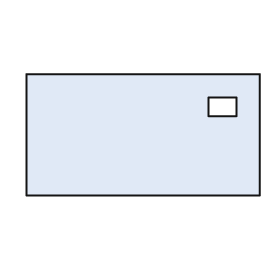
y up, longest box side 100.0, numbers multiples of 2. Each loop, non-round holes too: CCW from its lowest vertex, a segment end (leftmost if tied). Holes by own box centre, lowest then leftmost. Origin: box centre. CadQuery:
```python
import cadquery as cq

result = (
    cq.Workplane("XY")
    .moveTo(-50.0, -26.0)
    .lineTo(50.0, -26.0)
    .lineTo(50.0, 26.0)
    .lineTo(-50.0, 26.0)
    .close()
    .moveTo(28.0, 8.0)
    .lineTo(40.0, 8.0)
    .lineTo(40.0, 16.0)
    .lineTo(28.0, 16.0)
    .close()
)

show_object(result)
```